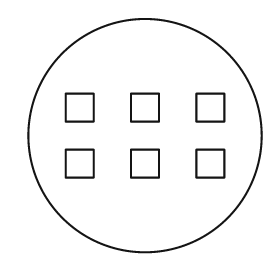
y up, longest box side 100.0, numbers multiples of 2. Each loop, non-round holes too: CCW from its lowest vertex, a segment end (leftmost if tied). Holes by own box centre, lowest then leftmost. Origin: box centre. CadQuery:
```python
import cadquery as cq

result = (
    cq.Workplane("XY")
    .moveTo(0.0, 0.0)
    .circle(50.0)
    .moveTo(-34.0, -18.0)
    .lineTo(-22.0, -18.0)
    .lineTo(-22.0, -6.0)
    .lineTo(-34.0, -6.0)
    .close()
    .moveTo(-6.0, -18.0)
    .lineTo(6.0, -18.0)
    .lineTo(6.0, -6.0)
    .lineTo(-6.0, -6.0)
    .close()
    .moveTo(22.0, -18.0)
    .lineTo(34.0, -18.0)
    .lineTo(34.0, -6.0)
    .lineTo(22.0, -6.0)
    .close()
    .moveTo(-34.0, 6.0)
    .lineTo(-22.0, 6.0)
    .lineTo(-22.0, 18.0)
    .lineTo(-34.0, 18.0)
    .close()
    .moveTo(-6.0, 6.0)
    .lineTo(6.0, 6.0)
    .lineTo(6.0, 18.0)
    .lineTo(-6.0, 18.0)
    .close()
    .moveTo(22.0, 6.0)
    .lineTo(34.0, 6.0)
    .lineTo(34.0, 18.0)
    .lineTo(22.0, 18.0)
    .close()
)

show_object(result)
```